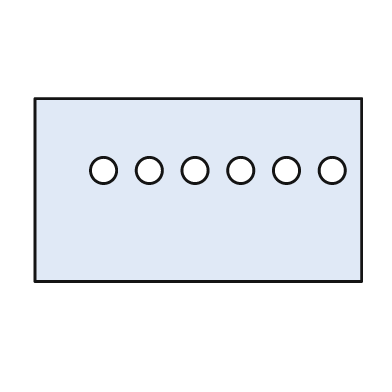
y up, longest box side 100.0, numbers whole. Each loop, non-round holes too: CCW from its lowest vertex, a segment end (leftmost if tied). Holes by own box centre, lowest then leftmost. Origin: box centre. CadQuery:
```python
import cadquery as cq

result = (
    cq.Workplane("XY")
    .moveTo(-50.0, -28.0)
    .lineTo(50.0, -28.0)
    .lineTo(50.0, 28.0)
    .lineTo(-50.0, 28.0)
    .close()
    .moveTo(-29.0, 6.0)
    .circle(4.0)
    .moveTo(-15.0, 6.0)
    .circle(4.0)
    .moveTo(-1.0, 6.0)
    .circle(4.0)
    .moveTo(13.0, 6.0)
    .circle(4.0)
    .moveTo(27.0, 6.0)
    .circle(4.0)
    .moveTo(41.0, 6.0)
    .circle(4.0)
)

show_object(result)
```